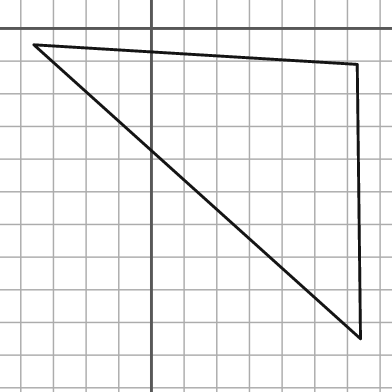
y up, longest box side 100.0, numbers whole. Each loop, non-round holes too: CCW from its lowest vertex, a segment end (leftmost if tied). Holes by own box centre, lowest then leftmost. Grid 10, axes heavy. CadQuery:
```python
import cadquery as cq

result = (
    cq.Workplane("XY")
    .moveTo(64.0, -95.0)
    .lineTo(63.0, -11.0)
    .lineTo(-36.0, -5.0)
    .close()
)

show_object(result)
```